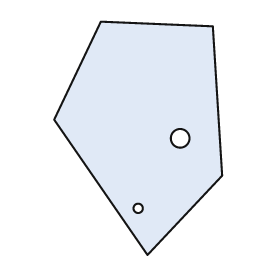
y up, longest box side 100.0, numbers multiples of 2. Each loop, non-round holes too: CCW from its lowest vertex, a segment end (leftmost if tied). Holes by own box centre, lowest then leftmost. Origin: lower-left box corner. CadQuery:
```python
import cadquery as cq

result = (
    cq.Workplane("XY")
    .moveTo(40.0, 0.0)
    .lineTo(72.0, 34.0)
    .lineTo(68.0, 98.0)
    .lineTo(20.0, 100.0)
    .lineTo(0.0, 58.0)
    .close()
    .moveTo(36.0, 20.0)
    .circle(2.0)
    .moveTo(54.0, 50.0)
    .circle(4.0)
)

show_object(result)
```